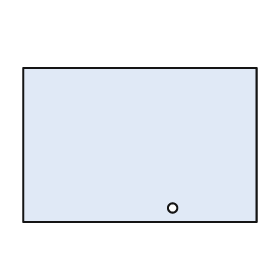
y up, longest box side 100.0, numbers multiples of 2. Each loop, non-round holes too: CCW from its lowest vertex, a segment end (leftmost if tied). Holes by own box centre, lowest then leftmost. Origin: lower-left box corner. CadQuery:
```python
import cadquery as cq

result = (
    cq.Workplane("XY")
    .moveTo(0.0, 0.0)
    .lineTo(100.0, 0.0)
    .lineTo(100.0, 66.0)
    .lineTo(0.0, 66.0)
    .close()
    .moveTo(64.0, 6.0)
    .circle(2.0)
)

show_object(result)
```